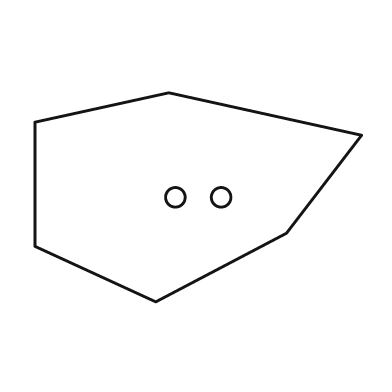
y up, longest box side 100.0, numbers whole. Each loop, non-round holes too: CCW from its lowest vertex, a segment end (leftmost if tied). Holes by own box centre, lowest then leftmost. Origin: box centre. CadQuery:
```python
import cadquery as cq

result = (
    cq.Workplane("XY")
    .moveTo(-13.0, -32.0)
    .lineTo(27.0, -11.0)
    .lineTo(50.0, 19.0)
    .lineTo(-9.0, 32.0)
    .lineTo(-50.0, 23.0)
    .lineTo(-50.0, -15.0)
    .close()
    .moveTo(-7.0, 0.0)
    .circle(3.0)
    .moveTo(7.0, 0.0)
    .circle(3.0)
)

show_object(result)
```